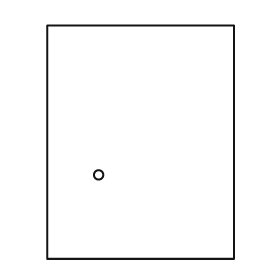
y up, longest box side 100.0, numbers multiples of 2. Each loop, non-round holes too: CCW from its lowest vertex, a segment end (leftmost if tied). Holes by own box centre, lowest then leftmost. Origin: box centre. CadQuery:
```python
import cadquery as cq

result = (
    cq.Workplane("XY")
    .moveTo(-40.0, -50.0)
    .lineTo(40.0, -50.0)
    .lineTo(40.0, 50.0)
    .lineTo(-40.0, 50.0)
    .close()
    .moveTo(-18.0, -14.0)
    .circle(2.0)
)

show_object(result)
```